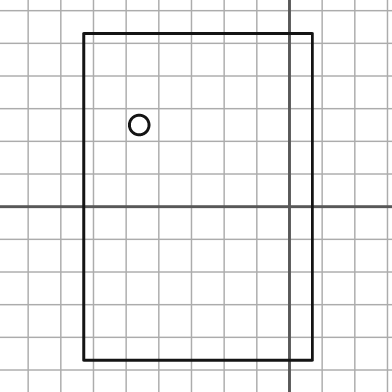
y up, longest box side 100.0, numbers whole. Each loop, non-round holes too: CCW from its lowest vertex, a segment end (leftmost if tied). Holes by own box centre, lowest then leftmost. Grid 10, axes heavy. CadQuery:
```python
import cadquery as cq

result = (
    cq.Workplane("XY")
    .moveTo(-63.0, -47.0)
    .lineTo(7.0, -47.0)
    .lineTo(7.0, 53.0)
    .lineTo(-63.0, 53.0)
    .close()
    .moveTo(-46.0, 25.0)
    .circle(3.0)
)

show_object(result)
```